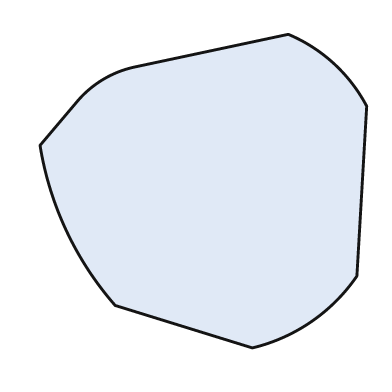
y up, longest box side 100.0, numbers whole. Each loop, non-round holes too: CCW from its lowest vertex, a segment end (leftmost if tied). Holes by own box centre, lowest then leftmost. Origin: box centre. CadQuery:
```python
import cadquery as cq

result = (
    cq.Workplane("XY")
    .moveTo(15.0, -48.0)
    .threePointArc((33.0, -40.0), (47.0, -26.0))
    .lineTo(50.0, 26.0)
    .threePointArc((40.0, 39.0), (26.0, 48.0))
    .lineTo(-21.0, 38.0)
    .threePointArc((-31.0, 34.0), (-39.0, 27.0))
    .lineTo(-50.0, 14.0)
    .threePointArc((-42.0, -12.0), (-27.0, -35.0))
    .close()
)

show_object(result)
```